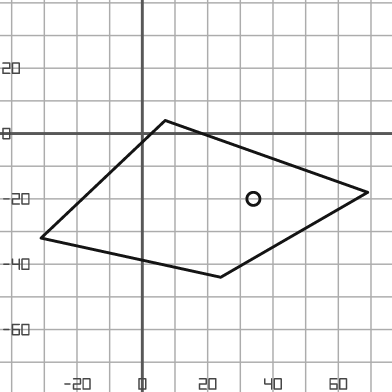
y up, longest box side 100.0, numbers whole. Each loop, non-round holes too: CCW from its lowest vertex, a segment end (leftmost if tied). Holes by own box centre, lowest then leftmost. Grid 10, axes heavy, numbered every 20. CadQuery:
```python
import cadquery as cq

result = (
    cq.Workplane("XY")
    .moveTo(24.0, -44.0)
    .lineTo(69.0, -18.0)
    .lineTo(7.0, 4.0)
    .lineTo(-31.0, -32.0)
    .close()
    .moveTo(34.0, -20.0)
    .circle(2.0)
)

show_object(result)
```